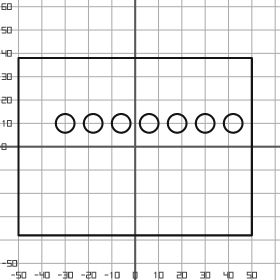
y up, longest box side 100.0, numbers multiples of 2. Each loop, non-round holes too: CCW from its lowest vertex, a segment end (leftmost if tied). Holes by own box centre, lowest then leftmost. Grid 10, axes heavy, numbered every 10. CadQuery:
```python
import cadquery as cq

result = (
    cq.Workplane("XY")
    .moveTo(-50.0, -38.0)
    .lineTo(50.0, -38.0)
    .lineTo(50.0, 38.0)
    .lineTo(-50.0, 38.0)
    .close()
    .moveTo(-30.0, 10.0)
    .circle(4.0)
    .moveTo(-18.0, 10.0)
    .circle(4.0)
    .moveTo(-6.0, 10.0)
    .circle(4.0)
    .moveTo(6.0, 10.0)
    .circle(4.0)
    .moveTo(18.0, 10.0)
    .circle(4.0)
    .moveTo(30.0, 10.0)
    .circle(4.0)
    .moveTo(42.0, 10.0)
    .circle(4.0)
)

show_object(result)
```